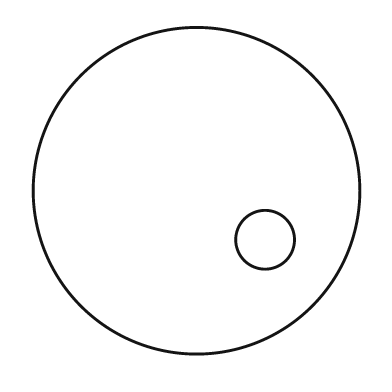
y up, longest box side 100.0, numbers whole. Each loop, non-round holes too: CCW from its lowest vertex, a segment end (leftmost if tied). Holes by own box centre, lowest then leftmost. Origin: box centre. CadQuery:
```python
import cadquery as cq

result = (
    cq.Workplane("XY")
    .moveTo(0.0, 0.0)
    .circle(50.0)
    .moveTo(21.0, -15.0)
    .circle(9.0)
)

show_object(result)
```